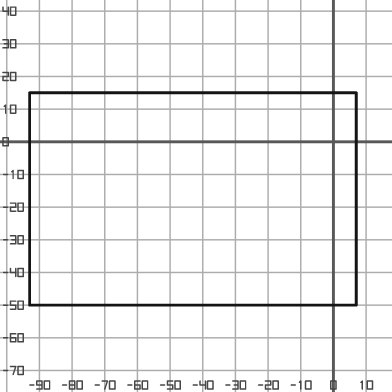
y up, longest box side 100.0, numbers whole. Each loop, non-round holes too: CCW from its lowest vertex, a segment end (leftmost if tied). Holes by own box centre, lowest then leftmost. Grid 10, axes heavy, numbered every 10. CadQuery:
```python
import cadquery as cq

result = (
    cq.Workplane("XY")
    .moveTo(-93.0, -50.0)
    .lineTo(7.0, -50.0)
    .lineTo(7.0, 15.0)
    .lineTo(-93.0, 15.0)
    .close()
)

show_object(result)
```